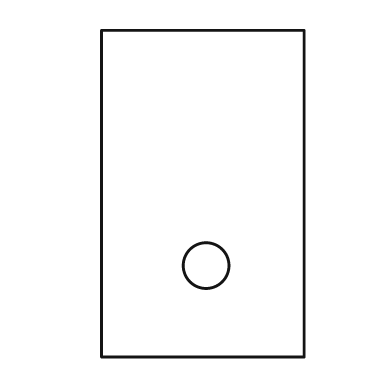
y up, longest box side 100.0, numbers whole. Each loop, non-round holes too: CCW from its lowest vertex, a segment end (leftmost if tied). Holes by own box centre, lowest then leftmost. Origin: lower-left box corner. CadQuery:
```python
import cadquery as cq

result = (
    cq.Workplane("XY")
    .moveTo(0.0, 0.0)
    .lineTo(62.0, 0.0)
    .lineTo(62.0, 100.0)
    .lineTo(0.0, 100.0)
    .close()
    .moveTo(32.0, 28.0)
    .circle(7.0)
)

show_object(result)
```